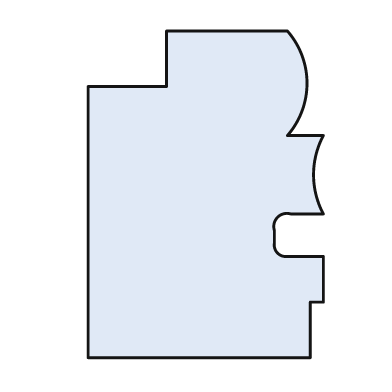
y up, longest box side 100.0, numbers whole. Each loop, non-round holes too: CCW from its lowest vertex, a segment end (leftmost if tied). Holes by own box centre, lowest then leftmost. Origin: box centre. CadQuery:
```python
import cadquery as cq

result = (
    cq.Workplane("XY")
    .moveTo(-36.0, -50.0)
    .lineTo(32.0, -50.0)
    .lineTo(32.0, -33.0)
    .lineTo(36.0, -33.0)
    .lineTo(36.0, -19.0)
    .lineTo(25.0, -19.0)
    .threePointArc((22.0, -18.0), (21.0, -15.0))
    .lineTo(21.0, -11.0)
    .threePointArc((22.0, -7.0), (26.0, -6.0))
    .lineTo(36.0, -6.0)
    .threePointArc((33.0, 6.0), (36.0, 18.0))
    .lineTo(25.0, 18.0)
    .threePointArc((31.0, 34.0), (25.0, 50.0))
    .lineTo(-12.0, 50.0)
    .lineTo(-12.0, 33.0)
    .lineTo(-36.0, 33.0)
    .close()
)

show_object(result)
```